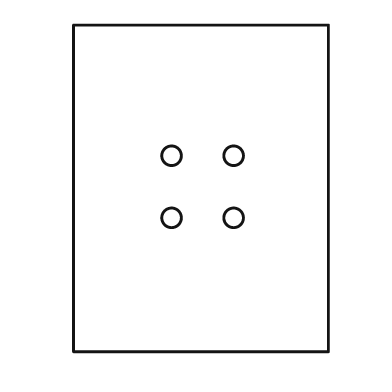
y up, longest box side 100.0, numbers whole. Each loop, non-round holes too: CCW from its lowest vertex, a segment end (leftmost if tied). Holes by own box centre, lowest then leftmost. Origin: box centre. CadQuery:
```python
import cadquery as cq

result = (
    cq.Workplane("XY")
    .moveTo(-39.0, -50.0)
    .lineTo(39.0, -50.0)
    .lineTo(39.0, 50.0)
    .lineTo(-39.0, 50.0)
    .close()
    .moveTo(-9.0, -9.0)
    .circle(3.0)
    .moveTo(10.0, -9.0)
    .circle(3.0)
    .moveTo(-9.0, 10.0)
    .circle(3.0)
    .moveTo(10.0, 10.0)
    .circle(3.0)
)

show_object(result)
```